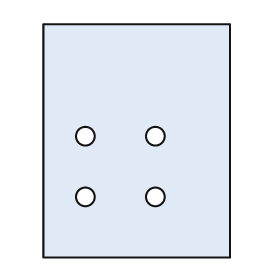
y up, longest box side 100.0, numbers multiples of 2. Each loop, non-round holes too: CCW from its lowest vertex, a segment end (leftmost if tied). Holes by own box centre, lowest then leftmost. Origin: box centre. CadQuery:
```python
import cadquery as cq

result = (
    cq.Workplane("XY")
    .moveTo(-40.0, -50.0)
    .lineTo(40.0, -50.0)
    .lineTo(40.0, 50.0)
    .lineTo(-40.0, 50.0)
    .close()
    .moveTo(-22.0, -24.0)
    .circle(4.0)
    .moveTo(8.0, -24.0)
    .circle(4.0)
    .moveTo(-22.0, 2.0)
    .circle(4.0)
    .moveTo(8.0, 2.0)
    .circle(4.0)
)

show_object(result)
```